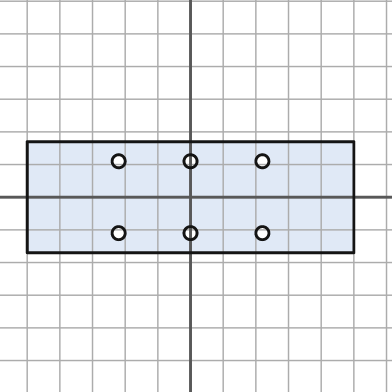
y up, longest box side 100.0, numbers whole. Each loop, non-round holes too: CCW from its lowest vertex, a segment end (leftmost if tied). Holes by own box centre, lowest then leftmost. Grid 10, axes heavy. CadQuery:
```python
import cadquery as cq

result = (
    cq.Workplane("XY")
    .moveTo(-50.0, -17.0)
    .lineTo(50.0, -17.0)
    .lineTo(50.0, 17.0)
    .lineTo(-50.0, 17.0)
    .close()
    .moveTo(-22.0, -11.0)
    .circle(2.0)
    .moveTo(0.0, -11.0)
    .circle(2.0)
    .moveTo(22.0, -11.0)
    .circle(2.0)
    .moveTo(-22.0, 11.0)
    .circle(2.0)
    .moveTo(0.0, 11.0)
    .circle(2.0)
    .moveTo(22.0, 11.0)
    .circle(2.0)
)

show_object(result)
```